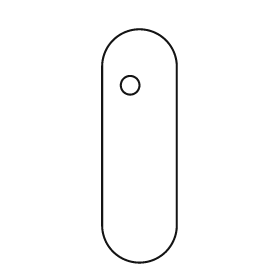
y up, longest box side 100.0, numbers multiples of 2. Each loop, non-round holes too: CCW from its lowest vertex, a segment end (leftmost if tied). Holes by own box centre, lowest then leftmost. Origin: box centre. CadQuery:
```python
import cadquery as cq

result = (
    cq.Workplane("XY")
    .moveTo(-16.0, -34.0)
    .threePointArc((0.0, -50.0), (16.0, -34.0))
    .lineTo(16.0, 34.0)
    .threePointArc((0.0, 50.0), (-16.0, 34.0))
    .close()
    .moveTo(-4.0, 26.0)
    .circle(4.0)
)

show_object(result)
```